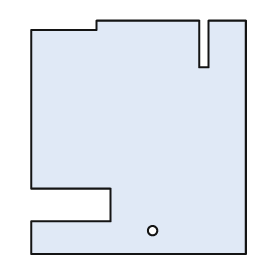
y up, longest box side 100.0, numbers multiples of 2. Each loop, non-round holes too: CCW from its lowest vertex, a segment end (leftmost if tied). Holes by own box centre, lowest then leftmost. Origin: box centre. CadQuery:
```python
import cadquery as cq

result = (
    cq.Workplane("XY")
    .moveTo(-46.0, -50.0)
    .lineTo(46.0, -50.0)
    .lineTo(46.0, 50.0)
    .lineTo(30.0, 50.0)
    .lineTo(30.0, 30.0)
    .lineTo(26.0, 30.0)
    .lineTo(26.0, 50.0)
    .lineTo(-18.0, 50.0)
    .lineTo(-18.0, 46.0)
    .lineTo(-46.0, 46.0)
    .lineTo(-46.0, -22.0)
    .lineTo(-12.0, -22.0)
    .lineTo(-12.0, -36.0)
    .lineTo(-46.0, -36.0)
    .close()
    .moveTo(6.0, -40.0)
    .circle(2.0)
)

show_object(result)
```